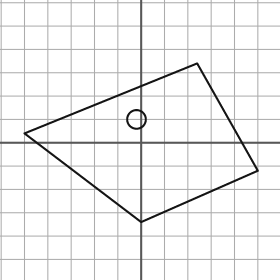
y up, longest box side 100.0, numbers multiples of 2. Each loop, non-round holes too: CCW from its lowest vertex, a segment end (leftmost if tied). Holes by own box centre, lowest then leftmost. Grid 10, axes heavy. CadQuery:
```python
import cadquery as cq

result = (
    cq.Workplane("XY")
    .moveTo(0.0, -34.0)
    .lineTo(50.0, -12.0)
    .lineTo(24.0, 34.0)
    .lineTo(-50.0, 4.0)
    .close()
    .moveTo(-2.0, 10.0)
    .circle(4.0)
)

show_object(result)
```